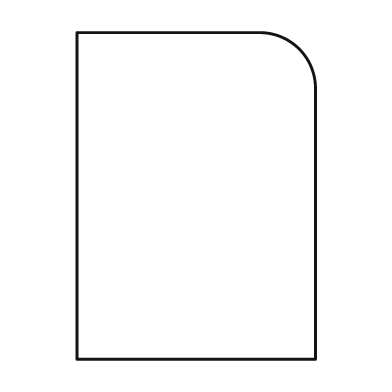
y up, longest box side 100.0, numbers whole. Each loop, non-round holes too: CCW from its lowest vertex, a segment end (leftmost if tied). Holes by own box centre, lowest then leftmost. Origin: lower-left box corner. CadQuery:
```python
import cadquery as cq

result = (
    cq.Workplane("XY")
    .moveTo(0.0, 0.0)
    .lineTo(73.0, 0.0)
    .lineTo(73.0, 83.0)
    .threePointArc((68.0, 95.0), (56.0, 100.0))
    .lineTo(0.0, 100.0)
    .close()
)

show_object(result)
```